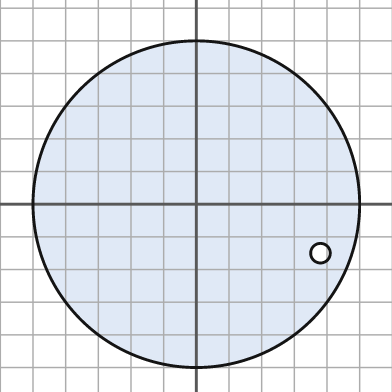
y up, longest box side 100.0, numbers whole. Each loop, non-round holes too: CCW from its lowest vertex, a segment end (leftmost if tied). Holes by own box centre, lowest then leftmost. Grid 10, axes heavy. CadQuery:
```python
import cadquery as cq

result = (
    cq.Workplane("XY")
    .moveTo(0.0, 0.0)
    .circle(50.0)
    .moveTo(38.0, -15.0)
    .circle(3.0)
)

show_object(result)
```